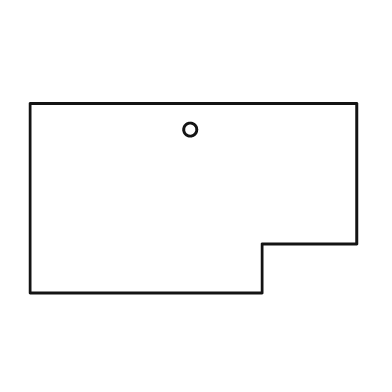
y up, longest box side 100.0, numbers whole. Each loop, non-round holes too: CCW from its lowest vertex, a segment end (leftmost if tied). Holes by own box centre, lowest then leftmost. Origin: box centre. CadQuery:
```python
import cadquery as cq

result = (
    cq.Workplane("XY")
    .moveTo(-50.0, -29.0)
    .lineTo(21.0, -29.0)
    .lineTo(21.0, -14.0)
    .lineTo(50.0, -14.0)
    .lineTo(50.0, 29.0)
    .lineTo(-50.0, 29.0)
    .close()
    .moveTo(-1.0, 21.0)
    .circle(2.0)
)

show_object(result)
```